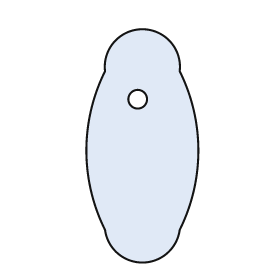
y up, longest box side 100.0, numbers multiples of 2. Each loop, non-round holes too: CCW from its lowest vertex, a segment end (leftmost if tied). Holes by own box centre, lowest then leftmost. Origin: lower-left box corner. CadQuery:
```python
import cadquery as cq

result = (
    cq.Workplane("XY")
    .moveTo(8.0, 14.0)
    .threePointArc((24.0, 0.0), (40.0, 14.0))
    .threePointArc((48.0, 48.0), (40.0, 82.0))
    .threePointArc((24.0, 100.0), (8.0, 82.0))
    .threePointArc((0.0, 48.0), (8.0, 14.0))
    .close()
    .moveTo(22.0, 70.0)
    .circle(4.0)
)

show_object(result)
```